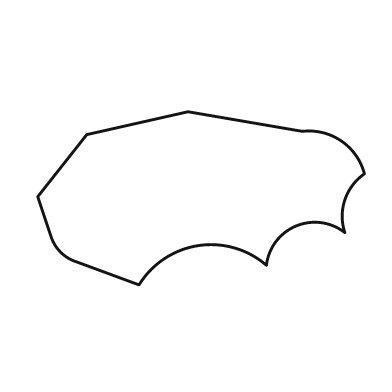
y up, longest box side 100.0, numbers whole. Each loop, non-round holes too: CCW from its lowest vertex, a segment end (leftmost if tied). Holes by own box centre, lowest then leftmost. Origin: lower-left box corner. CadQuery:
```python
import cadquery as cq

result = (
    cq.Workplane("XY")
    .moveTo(31.0, 0.0)
    .threePointArc((49.0, 12.0), (70.0, 6.0))
    .threePointArc((79.0, 18.0), (94.0, 16.0))
    .threePointArc((94.0, 26.0), (100.0, 34.0))
    .threePointArc((93.0, 44.0), (81.0, 47.0))
    .lineTo(46.0, 53.0)
    .lineTo(15.0, 46.0)
    .lineTo(0.0, 27.0)
    .lineTo(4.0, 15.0)
    .threePointArc((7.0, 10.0), (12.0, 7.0))
    .close()
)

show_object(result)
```